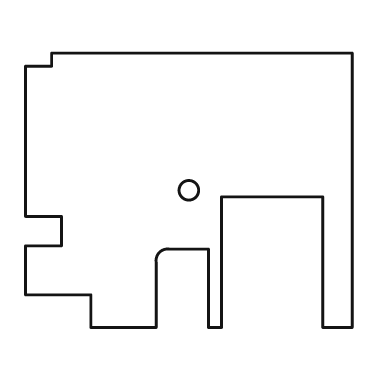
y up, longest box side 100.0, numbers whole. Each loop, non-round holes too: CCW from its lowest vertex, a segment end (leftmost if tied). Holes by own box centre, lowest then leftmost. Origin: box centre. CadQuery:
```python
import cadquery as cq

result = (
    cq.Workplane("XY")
    .moveTo(-30.0, -42.0)
    .lineTo(-10.0, -42.0)
    .lineTo(-10.0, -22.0)
    .threePointArc((-9.0, -19.0), (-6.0, -18.0))
    .lineTo(6.0, -18.0)
    .lineTo(6.0, -42.0)
    .lineTo(10.0, -42.0)
    .lineTo(10.0, -2.0)
    .lineTo(41.0, -2.0)
    .lineTo(41.0, -42.0)
    .lineTo(50.0, -42.0)
    .lineTo(50.0, 42.0)
    .lineTo(-42.0, 42.0)
    .lineTo(-42.0, 38.0)
    .lineTo(-50.0, 38.0)
    .lineTo(-50.0, -8.0)
    .lineTo(-39.0, -8.0)
    .lineTo(-39.0, -17.0)
    .lineTo(-50.0, -17.0)
    .lineTo(-50.0, -32.0)
    .lineTo(-30.0, -32.0)
    .close()
    .moveTo(0.0, 0.0)
    .circle(3.0)
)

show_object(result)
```